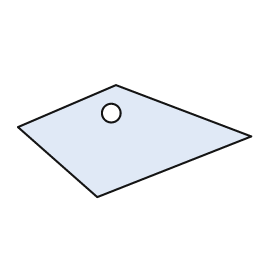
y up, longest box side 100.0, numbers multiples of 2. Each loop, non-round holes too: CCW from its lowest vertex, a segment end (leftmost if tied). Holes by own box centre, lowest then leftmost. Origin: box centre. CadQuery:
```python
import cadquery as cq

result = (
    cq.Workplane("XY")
    .moveTo(-16.0, -24.0)
    .lineTo(50.0, 2.0)
    .lineTo(-8.0, 24.0)
    .lineTo(-50.0, 6.0)
    .close()
    .moveTo(-10.0, 12.0)
    .circle(4.0)
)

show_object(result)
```